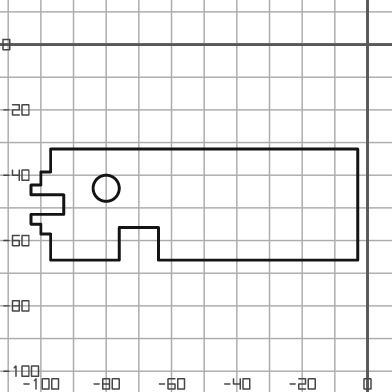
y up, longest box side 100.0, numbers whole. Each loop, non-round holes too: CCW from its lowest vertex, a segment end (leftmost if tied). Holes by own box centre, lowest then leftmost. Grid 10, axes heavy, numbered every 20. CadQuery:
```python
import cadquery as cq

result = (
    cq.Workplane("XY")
    .moveTo(-97.0, -66.0)
    .lineTo(-76.0, -66.0)
    .lineTo(-76.0, -56.0)
    .lineTo(-64.0, -56.0)
    .lineTo(-64.0, -66.0)
    .lineTo(-3.0, -66.0)
    .lineTo(-3.0, -32.0)
    .lineTo(-97.0, -32.0)
    .lineTo(-97.0, -39.0)
    .lineTo(-100.0, -39.0)
    .lineTo(-100.0, -43.0)
    .lineTo(-103.0, -43.0)
    .lineTo(-103.0, -46.0)
    .lineTo(-93.0, -46.0)
    .lineTo(-93.0, -52.0)
    .lineTo(-103.0, -52.0)
    .lineTo(-103.0, -55.0)
    .lineTo(-100.0, -55.0)
    .lineTo(-100.0, -58.0)
    .lineTo(-97.0, -58.0)
    .close()
    .moveTo(-80.0, -44.0)
    .circle(4.0)
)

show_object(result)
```